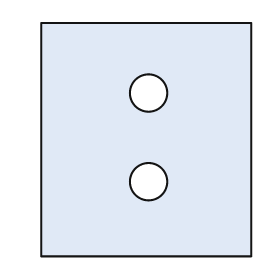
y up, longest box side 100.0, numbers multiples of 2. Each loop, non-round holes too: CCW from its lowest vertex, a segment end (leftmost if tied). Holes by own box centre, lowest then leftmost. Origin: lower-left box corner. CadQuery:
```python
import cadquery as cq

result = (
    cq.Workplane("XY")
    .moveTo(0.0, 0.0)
    .lineTo(90.0, 0.0)
    .lineTo(90.0, 100.0)
    .lineTo(0.0, 100.0)
    .close()
    .moveTo(46.0, 32.0)
    .circle(8.0)
    .moveTo(46.0, 70.0)
    .circle(8.0)
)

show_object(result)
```